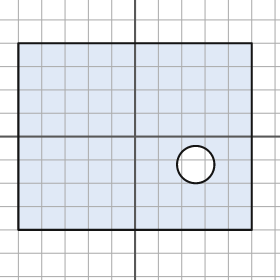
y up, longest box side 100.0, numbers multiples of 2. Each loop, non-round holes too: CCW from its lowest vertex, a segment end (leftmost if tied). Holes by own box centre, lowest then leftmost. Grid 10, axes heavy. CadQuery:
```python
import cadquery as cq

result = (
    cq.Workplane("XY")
    .moveTo(-50.0, -40.0)
    .lineTo(50.0, -40.0)
    .lineTo(50.0, 40.0)
    .lineTo(-50.0, 40.0)
    .close()
    .moveTo(26.0, -12.0)
    .circle(8.0)
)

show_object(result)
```